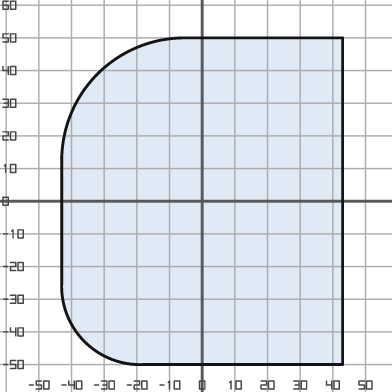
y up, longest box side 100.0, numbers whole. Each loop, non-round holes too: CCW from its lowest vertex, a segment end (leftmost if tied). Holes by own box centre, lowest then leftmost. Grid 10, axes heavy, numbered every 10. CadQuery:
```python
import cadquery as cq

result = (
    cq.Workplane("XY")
    .moveTo(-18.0, -50.0)
    .lineTo(43.0, -50.0)
    .lineTo(43.0, 50.0)
    .lineTo(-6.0, 50.0)
    .threePointArc((-32.0, 39.0), (-43.0, 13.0))
    .lineTo(-43.0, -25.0)
    .threePointArc((-36.0, -43.0), (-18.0, -50.0))
    .close()
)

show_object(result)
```